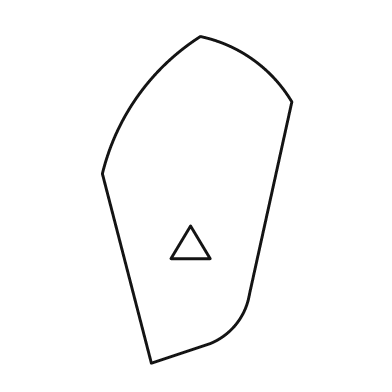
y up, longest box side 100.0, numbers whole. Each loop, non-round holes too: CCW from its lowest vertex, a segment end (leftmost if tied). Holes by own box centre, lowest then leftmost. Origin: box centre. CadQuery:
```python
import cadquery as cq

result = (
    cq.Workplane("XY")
    .moveTo(-14.0, -50.0)
    .lineTo(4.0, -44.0)
    .threePointArc((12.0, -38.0), (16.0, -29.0))
    .lineTo(29.0, 30.0)
    .threePointArc((17.0, 43.0), (1.0, 50.0))
    .threePointArc((-18.0, 32.0), (-29.0, 8.0))
    .close()
    .moveTo(-8.0, -18.0)
    .lineTo(4.0, -18.0)
    .lineTo(-2.0, -8.0)
    .close()
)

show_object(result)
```